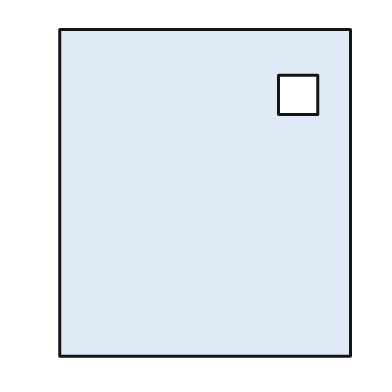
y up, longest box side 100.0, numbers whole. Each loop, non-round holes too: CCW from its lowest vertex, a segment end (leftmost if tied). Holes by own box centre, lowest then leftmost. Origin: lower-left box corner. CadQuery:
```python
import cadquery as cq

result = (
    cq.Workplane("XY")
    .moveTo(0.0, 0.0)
    .lineTo(89.0, 0.0)
    .lineTo(89.0, 100.0)
    .lineTo(0.0, 100.0)
    .close()
    .moveTo(67.0, 74.0)
    .lineTo(79.0, 74.0)
    .lineTo(79.0, 86.0)
    .lineTo(67.0, 86.0)
    .close()
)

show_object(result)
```